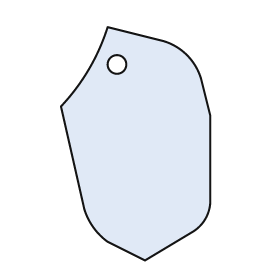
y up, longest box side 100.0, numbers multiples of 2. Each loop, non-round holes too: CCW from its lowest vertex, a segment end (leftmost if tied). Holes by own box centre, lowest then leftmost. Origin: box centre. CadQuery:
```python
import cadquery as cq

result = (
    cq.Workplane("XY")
    .moveTo(4.0, -50.0)
    .lineTo(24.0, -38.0)
    .threePointArc((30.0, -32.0), (32.0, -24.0))
    .lineTo(32.0, 12.0)
    .lineTo(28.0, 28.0)
    .threePointArc((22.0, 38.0), (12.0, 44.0))
    .lineTo(-12.0, 50.0)
    .threePointArc((-20.0, 32.0), (-32.0, 16.0))
    .lineTo(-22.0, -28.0)
    .threePointArc((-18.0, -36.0), (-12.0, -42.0))
    .close()
    .moveTo(-8.0, 34.0)
    .circle(4.0)
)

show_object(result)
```